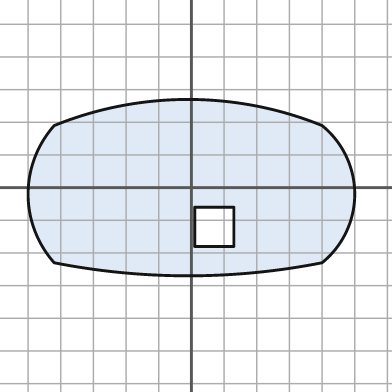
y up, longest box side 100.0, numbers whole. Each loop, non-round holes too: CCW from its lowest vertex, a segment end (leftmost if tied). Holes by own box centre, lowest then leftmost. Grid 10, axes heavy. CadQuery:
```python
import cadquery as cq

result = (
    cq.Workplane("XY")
    .moveTo(-42.0, -23.0)
    .threePointArc((-1.0, -27.0), (40.0, -23.0))
    .threePointArc((50.0, -2.0), (40.0, 19.0))
    .threePointArc((-1.0, 27.0), (-42.0, 19.0))
    .threePointArc((-50.0, -2.0), (-42.0, -23.0))
    .close()
    .moveTo(1.0, -18.0)
    .lineTo(13.0, -18.0)
    .lineTo(13.0, -6.0)
    .lineTo(1.0, -6.0)
    .close()
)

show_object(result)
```